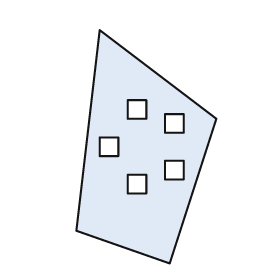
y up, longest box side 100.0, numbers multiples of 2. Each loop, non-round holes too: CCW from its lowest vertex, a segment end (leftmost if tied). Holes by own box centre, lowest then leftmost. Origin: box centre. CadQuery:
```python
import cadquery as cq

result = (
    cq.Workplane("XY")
    .moveTo(10.0, -50.0)
    .lineTo(30.0, 12.0)
    .lineTo(-20.0, 50.0)
    .lineTo(-30.0, -36.0)
    .close()
    .moveTo(-8.0, -20.0)
    .lineTo(0.0, -20.0)
    .lineTo(0.0, -12.0)
    .lineTo(-8.0, -12.0)
    .close()
    .moveTo(8.0, -14.0)
    .lineTo(16.0, -14.0)
    .lineTo(16.0, -6.0)
    .lineTo(8.0, -6.0)
    .close()
    .moveTo(-20.0, -4.0)
    .lineTo(-12.0, -4.0)
    .lineTo(-12.0, 4.0)
    .lineTo(-20.0, 4.0)
    .close()
    .moveTo(8.0, 6.0)
    .lineTo(16.0, 6.0)
    .lineTo(16.0, 14.0)
    .lineTo(8.0, 14.0)
    .close()
    .moveTo(-8.0, 12.0)
    .lineTo(0.0, 12.0)
    .lineTo(0.0, 20.0)
    .lineTo(-8.0, 20.0)
    .close()
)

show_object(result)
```